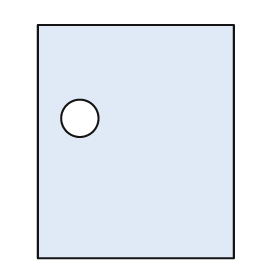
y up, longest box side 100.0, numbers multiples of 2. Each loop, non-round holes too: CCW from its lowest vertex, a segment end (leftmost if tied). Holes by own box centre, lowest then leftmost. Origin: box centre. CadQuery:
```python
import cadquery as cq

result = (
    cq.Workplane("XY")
    .moveTo(-42.0, -50.0)
    .lineTo(42.0, -50.0)
    .lineTo(42.0, 50.0)
    .lineTo(-42.0, 50.0)
    .close()
    .moveTo(-24.0, 10.0)
    .circle(8.0)
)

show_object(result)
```